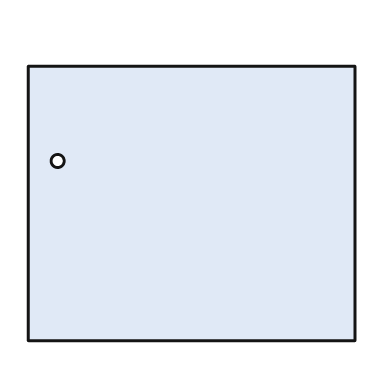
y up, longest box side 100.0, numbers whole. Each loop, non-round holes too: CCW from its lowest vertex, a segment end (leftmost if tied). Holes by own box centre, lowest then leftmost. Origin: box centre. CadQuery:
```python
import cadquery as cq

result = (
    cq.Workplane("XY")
    .moveTo(-50.0, -42.0)
    .lineTo(50.0, -42.0)
    .lineTo(50.0, 42.0)
    .lineTo(-50.0, 42.0)
    .close()
    .moveTo(-41.0, 13.0)
    .circle(2.0)
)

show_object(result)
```